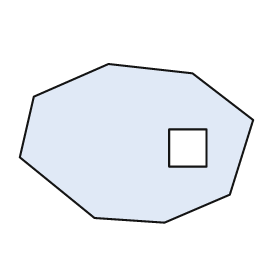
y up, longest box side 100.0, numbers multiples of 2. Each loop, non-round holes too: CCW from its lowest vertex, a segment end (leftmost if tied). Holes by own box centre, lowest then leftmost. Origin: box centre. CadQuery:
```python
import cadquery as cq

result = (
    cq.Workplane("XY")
    .moveTo(12.0, -34.0)
    .lineTo(40.0, -22.0)
    .lineTo(50.0, 10.0)
    .lineTo(24.0, 30.0)
    .lineTo(-12.0, 34.0)
    .lineTo(-44.0, 20.0)
    .lineTo(-50.0, -6.0)
    .lineTo(-18.0, -32.0)
    .close()
    .moveTo(14.0, -10.0)
    .lineTo(30.0, -10.0)
    .lineTo(30.0, 6.0)
    .lineTo(14.0, 6.0)
    .close()
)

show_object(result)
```